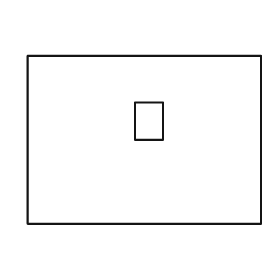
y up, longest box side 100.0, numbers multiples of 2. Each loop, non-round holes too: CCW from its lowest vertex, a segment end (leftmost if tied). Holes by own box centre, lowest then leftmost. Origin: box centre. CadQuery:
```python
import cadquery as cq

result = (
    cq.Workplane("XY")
    .moveTo(-50.0, -36.0)
    .lineTo(50.0, -36.0)
    .lineTo(50.0, 36.0)
    .lineTo(-50.0, 36.0)
    .close()
    .moveTo(-4.0, 0.0)
    .lineTo(8.0, 0.0)
    .lineTo(8.0, 16.0)
    .lineTo(-4.0, 16.0)
    .close()
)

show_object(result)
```